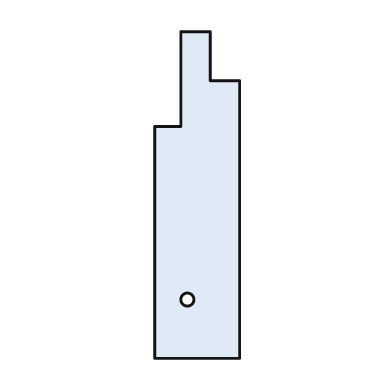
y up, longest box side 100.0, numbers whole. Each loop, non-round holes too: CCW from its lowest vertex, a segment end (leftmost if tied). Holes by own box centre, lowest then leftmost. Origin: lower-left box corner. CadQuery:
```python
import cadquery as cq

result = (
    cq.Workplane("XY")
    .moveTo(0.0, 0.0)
    .lineTo(26.0, 0.0)
    .lineTo(26.0, 85.0)
    .lineTo(17.0, 85.0)
    .lineTo(17.0, 100.0)
    .lineTo(8.0, 100.0)
    .lineTo(8.0, 71.0)
    .lineTo(0.0, 71.0)
    .close()
    .moveTo(10.0, 18.0)
    .circle(2.0)
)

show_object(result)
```